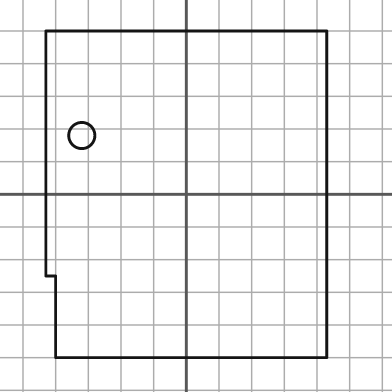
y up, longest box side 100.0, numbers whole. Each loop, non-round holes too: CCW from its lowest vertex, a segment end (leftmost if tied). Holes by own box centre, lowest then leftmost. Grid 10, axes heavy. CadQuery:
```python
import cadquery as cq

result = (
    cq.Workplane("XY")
    .moveTo(-40.0, -50.0)
    .lineTo(43.0, -50.0)
    .lineTo(43.0, 50.0)
    .lineTo(-43.0, 50.0)
    .lineTo(-43.0, -25.0)
    .lineTo(-40.0, -25.0)
    .close()
    .moveTo(-32.0, 18.0)
    .circle(4.0)
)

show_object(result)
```